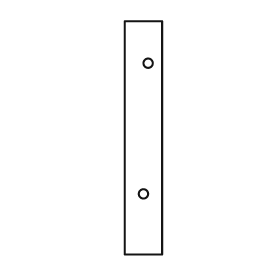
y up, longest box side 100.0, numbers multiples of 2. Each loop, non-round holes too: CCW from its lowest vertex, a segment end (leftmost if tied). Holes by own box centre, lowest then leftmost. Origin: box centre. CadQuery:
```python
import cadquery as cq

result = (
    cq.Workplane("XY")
    .moveTo(-8.0, -50.0)
    .lineTo(8.0, -50.0)
    .lineTo(8.0, 50.0)
    .lineTo(-8.0, 50.0)
    .close()
    .moveTo(0.0, -24.0)
    .circle(2.0)
    .moveTo(2.0, 32.0)
    .circle(2.0)
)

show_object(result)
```